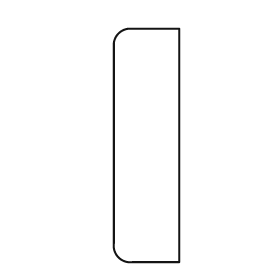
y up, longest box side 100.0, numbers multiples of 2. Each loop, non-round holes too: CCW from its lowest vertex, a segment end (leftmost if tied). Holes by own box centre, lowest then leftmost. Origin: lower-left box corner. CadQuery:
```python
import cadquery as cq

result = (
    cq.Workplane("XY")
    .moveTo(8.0, 0.0)
    .lineTo(28.0, 0.0)
    .lineTo(28.0, 100.0)
    .lineTo(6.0, 100.0)
    .threePointArc((2.0, 98.0), (0.0, 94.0))
    .lineTo(0.0, 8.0)
    .threePointArc((2.0, 2.0), (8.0, 0.0))
    .close()
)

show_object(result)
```